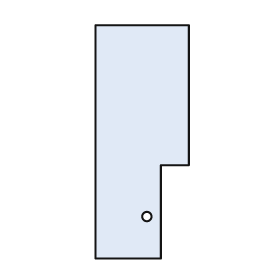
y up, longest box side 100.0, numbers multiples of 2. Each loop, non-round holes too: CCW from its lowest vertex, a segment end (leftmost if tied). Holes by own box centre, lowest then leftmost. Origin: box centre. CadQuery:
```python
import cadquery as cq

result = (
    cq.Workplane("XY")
    .moveTo(-20.0, -50.0)
    .lineTo(8.0, -50.0)
    .lineTo(8.0, -10.0)
    .lineTo(20.0, -10.0)
    .lineTo(20.0, 50.0)
    .lineTo(-20.0, 50.0)
    .close()
    .moveTo(2.0, -32.0)
    .circle(2.0)
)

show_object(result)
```